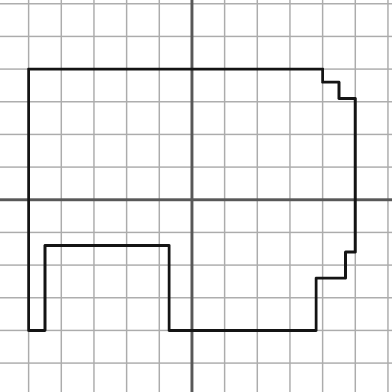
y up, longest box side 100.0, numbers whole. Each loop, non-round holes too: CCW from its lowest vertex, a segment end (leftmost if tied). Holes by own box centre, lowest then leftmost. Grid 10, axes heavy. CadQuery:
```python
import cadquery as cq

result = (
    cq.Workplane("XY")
    .moveTo(-50.0, -40.0)
    .lineTo(-45.0, -40.0)
    .lineTo(-45.0, -14.0)
    .lineTo(-7.0, -14.0)
    .lineTo(-7.0, -40.0)
    .lineTo(38.0, -40.0)
    .lineTo(38.0, -24.0)
    .lineTo(47.0, -24.0)
    .lineTo(47.0, -16.0)
    .lineTo(50.0, -16.0)
    .lineTo(50.0, 31.0)
    .lineTo(45.0, 31.0)
    .lineTo(45.0, 36.0)
    .lineTo(40.0, 36.0)
    .lineTo(40.0, 40.0)
    .lineTo(-50.0, 40.0)
    .close()
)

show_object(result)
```